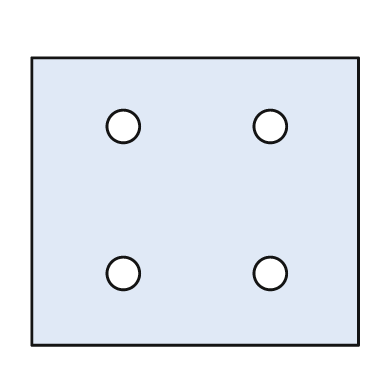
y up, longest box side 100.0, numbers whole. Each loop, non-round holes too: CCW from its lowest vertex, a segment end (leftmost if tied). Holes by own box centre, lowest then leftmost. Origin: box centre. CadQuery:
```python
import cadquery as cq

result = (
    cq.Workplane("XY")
    .moveTo(-50.0, -44.0)
    .lineTo(50.0, -44.0)
    .lineTo(50.0, 44.0)
    .lineTo(-50.0, 44.0)
    .close()
    .moveTo(-22.0, -22.0)
    .circle(5.0)
    .moveTo(23.0, -22.0)
    .circle(5.0)
    .moveTo(-22.0, 23.0)
    .circle(5.0)
    .moveTo(23.0, 23.0)
    .circle(5.0)
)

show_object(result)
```